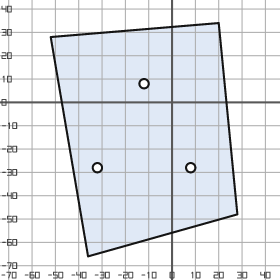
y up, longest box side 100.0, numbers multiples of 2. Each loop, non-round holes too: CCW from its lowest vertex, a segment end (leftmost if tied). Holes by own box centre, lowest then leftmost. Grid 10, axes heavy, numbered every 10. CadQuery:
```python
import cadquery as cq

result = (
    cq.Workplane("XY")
    .moveTo(-36.0, -66.0)
    .lineTo(28.0, -48.0)
    .lineTo(20.0, 34.0)
    .lineTo(-52.0, 28.0)
    .close()
    .moveTo(-32.0, -28.0)
    .circle(2.0)
    .moveTo(8.0, -28.0)
    .circle(2.0)
    .moveTo(-12.0, 8.0)
    .circle(2.0)
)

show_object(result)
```